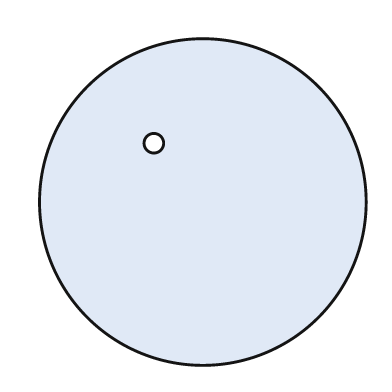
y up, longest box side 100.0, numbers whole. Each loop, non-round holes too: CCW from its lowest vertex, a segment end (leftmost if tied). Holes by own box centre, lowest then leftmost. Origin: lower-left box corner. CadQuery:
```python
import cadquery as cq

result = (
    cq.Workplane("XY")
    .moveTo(50.0, 50.0)
    .circle(50.0)
    .moveTo(35.0, 68.0)
    .circle(3.0)
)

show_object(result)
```